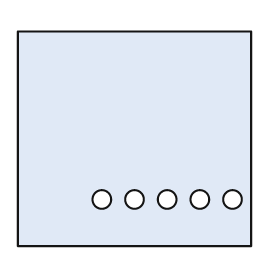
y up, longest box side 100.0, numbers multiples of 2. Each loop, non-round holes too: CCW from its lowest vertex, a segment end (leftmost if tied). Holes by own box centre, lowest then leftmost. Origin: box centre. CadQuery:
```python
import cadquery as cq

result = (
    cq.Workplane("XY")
    .moveTo(-50.0, -46.0)
    .lineTo(50.0, -46.0)
    .lineTo(50.0, 46.0)
    .lineTo(-50.0, 46.0)
    .close()
    .moveTo(-14.0, -26.0)
    .circle(4.0)
    .moveTo(0.0, -26.0)
    .circle(4.0)
    .moveTo(14.0, -26.0)
    .circle(4.0)
    .moveTo(28.0, -26.0)
    .circle(4.0)
    .moveTo(42.0, -26.0)
    .circle(4.0)
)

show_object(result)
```